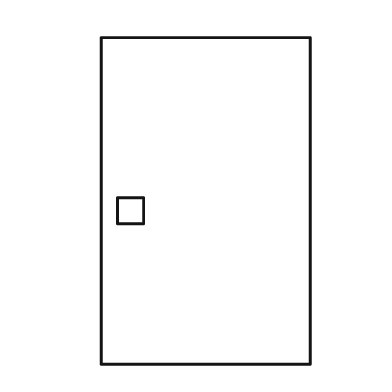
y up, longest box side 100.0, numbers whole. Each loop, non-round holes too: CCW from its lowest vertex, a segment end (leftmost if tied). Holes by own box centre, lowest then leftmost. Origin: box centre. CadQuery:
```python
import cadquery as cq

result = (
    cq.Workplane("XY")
    .moveTo(-32.0, -50.0)
    .lineTo(32.0, -50.0)
    .lineTo(32.0, 50.0)
    .lineTo(-32.0, 50.0)
    .close()
    .moveTo(-27.0, -7.0)
    .lineTo(-19.0, -7.0)
    .lineTo(-19.0, 1.0)
    .lineTo(-27.0, 1.0)
    .close()
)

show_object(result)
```